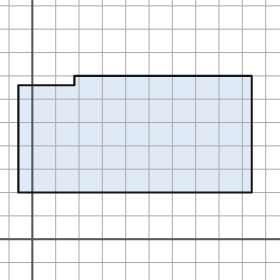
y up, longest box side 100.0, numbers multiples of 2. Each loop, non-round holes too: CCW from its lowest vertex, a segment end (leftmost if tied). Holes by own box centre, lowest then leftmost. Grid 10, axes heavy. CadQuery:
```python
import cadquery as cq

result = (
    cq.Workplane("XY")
    .moveTo(-6.0, 20.0)
    .lineTo(94.0, 20.0)
    .lineTo(94.0, 70.0)
    .lineTo(18.0, 70.0)
    .lineTo(18.0, 66.0)
    .lineTo(-6.0, 66.0)
    .close()
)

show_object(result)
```